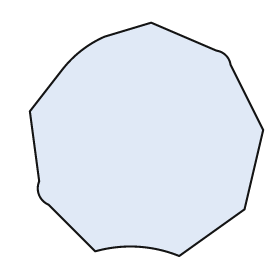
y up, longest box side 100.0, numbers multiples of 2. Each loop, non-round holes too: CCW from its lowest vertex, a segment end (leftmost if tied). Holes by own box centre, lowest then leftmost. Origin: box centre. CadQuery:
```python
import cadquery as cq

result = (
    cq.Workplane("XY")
    .moveTo(14.0, -50.0)
    .lineTo(42.0, -30.0)
    .lineTo(50.0, 4.0)
    .lineTo(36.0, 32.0)
    .threePointArc((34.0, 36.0), (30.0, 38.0))
    .lineTo(2.0, 50.0)
    .lineTo(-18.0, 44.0)
    .threePointArc((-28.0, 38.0), (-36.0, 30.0))
    .lineTo(-50.0, 12.0)
    .lineTo(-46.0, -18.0)
    .threePointArc((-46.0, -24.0), (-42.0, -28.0))
    .lineTo(-22.0, -48.0)
    .threePointArc((-4.0, -46.0), (14.0, -50.0))
    .close()
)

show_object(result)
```